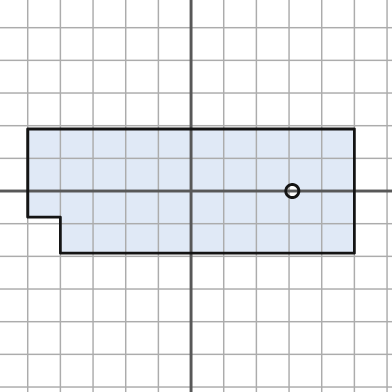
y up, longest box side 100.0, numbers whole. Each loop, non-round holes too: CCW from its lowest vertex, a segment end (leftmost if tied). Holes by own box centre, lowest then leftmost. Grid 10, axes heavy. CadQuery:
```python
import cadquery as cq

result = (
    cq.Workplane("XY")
    .moveTo(-40.0, -19.0)
    .lineTo(50.0, -19.0)
    .lineTo(50.0, 19.0)
    .lineTo(-50.0, 19.0)
    .lineTo(-50.0, -8.0)
    .lineTo(-40.0, -8.0)
    .close()
    .moveTo(31.0, 0.0)
    .circle(2.0)
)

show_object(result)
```